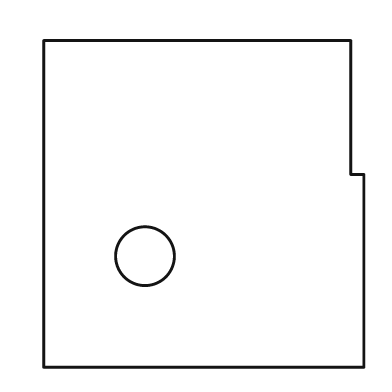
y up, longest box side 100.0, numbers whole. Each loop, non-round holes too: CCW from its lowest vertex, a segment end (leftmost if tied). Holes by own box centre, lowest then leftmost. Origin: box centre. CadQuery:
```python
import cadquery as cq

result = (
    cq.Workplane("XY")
    .moveTo(-49.0, -50.0)
    .lineTo(49.0, -50.0)
    .lineTo(49.0, 9.0)
    .lineTo(45.0, 9.0)
    .lineTo(45.0, 50.0)
    .lineTo(-49.0, 50.0)
    .close()
    .moveTo(-18.0, -16.0)
    .circle(9.0)
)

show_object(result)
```